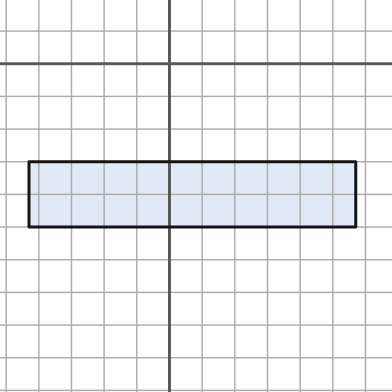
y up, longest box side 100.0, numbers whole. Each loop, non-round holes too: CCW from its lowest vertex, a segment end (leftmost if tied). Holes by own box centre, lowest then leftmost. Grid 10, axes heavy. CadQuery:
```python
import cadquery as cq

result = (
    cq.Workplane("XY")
    .moveTo(-43.0, -50.0)
    .lineTo(57.0, -50.0)
    .lineTo(57.0, -30.0)
    .lineTo(-43.0, -30.0)
    .close()
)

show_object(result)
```